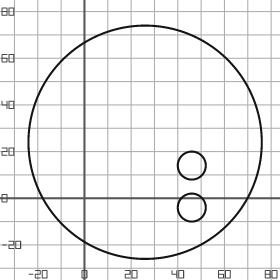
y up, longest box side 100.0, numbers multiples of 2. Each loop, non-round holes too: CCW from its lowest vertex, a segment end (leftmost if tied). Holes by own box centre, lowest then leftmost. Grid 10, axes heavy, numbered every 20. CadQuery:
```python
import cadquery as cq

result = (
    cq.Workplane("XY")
    .moveTo(26.0, 24.0)
    .circle(50.0)
    .moveTo(46.0, -4.0)
    .circle(6.0)
    .moveTo(46.0, 14.0)
    .circle(6.0)
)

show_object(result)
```